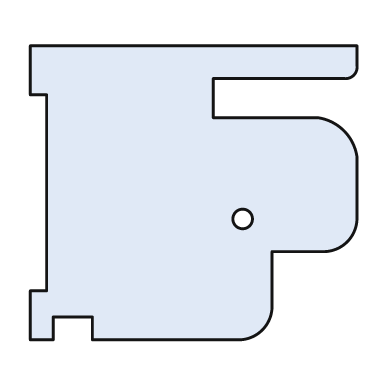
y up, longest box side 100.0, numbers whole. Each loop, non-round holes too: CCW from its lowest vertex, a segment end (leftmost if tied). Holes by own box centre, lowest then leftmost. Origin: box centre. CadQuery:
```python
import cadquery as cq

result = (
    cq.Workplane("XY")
    .moveTo(-50.0, -45.0)
    .lineTo(-43.0, -45.0)
    .lineTo(-43.0, -38.0)
    .lineTo(-31.0, -38.0)
    .lineTo(-31.0, -45.0)
    .lineTo(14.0, -45.0)
    .threePointArc((21.0, -42.0), (24.0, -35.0))
    .lineTo(24.0, -18.0)
    .lineTo(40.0, -18.0)
    .threePointArc((47.0, -15.0), (50.0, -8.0))
    .lineTo(50.0, 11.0)
    .threePointArc((46.0, 19.0), (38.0, 23.0))
    .lineTo(6.0, 23.0)
    .lineTo(6.0, 35.0)
    .lineTo(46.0, 35.0)
    .threePointArc((49.0, 36.0), (50.0, 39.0))
    .lineTo(50.0, 45.0)
    .lineTo(-50.0, 45.0)
    .lineTo(-50.0, 30.0)
    .lineTo(-45.0, 30.0)
    .lineTo(-45.0, -30.0)
    .lineTo(-50.0, -30.0)
    .close()
    .moveTo(15.0, -8.0)
    .circle(3.0)
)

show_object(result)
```